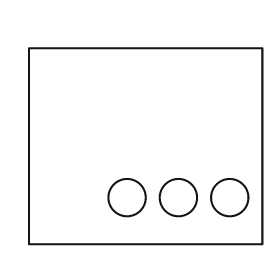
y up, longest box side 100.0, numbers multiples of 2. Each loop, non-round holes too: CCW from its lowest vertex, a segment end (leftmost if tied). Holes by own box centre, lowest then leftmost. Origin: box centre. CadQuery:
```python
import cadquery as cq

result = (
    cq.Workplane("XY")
    .moveTo(-50.0, -42.0)
    .lineTo(50.0, -42.0)
    .lineTo(50.0, 42.0)
    .lineTo(-50.0, 42.0)
    .close()
    .moveTo(-8.0, -22.0)
    .circle(8.0)
    .moveTo(14.0, -22.0)
    .circle(8.0)
    .moveTo(36.0, -22.0)
    .circle(8.0)
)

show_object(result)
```